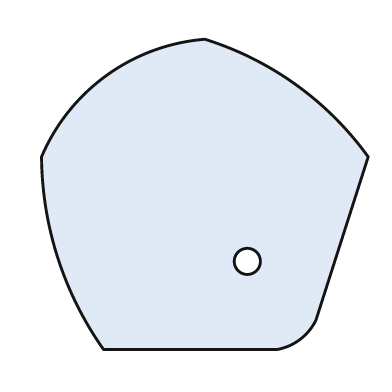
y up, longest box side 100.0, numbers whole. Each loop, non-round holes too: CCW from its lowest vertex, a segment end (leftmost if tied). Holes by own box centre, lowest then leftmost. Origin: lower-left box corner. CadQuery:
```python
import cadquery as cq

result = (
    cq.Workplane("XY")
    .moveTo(19.0, 0.0)
    .lineTo(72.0, 0.0)
    .threePointArc((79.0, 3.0), (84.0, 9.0))
    .lineTo(100.0, 59.0)
    .threePointArc((78.0, 81.0), (50.0, 95.0))
    .threePointArc((20.0, 84.0), (0.0, 59.0))
    .threePointArc((5.0, 28.0), (19.0, 0.0))
    .close()
    .moveTo(63.0, 27.0)
    .circle(4.0)
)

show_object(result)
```